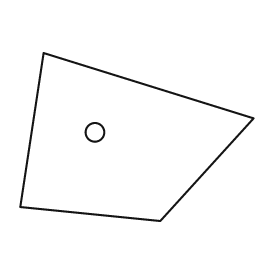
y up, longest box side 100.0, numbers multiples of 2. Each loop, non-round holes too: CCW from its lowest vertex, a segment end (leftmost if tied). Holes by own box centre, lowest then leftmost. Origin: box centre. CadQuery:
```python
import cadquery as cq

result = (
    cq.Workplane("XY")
    .moveTo(10.0, -36.0)
    .lineTo(50.0, 8.0)
    .lineTo(-40.0, 36.0)
    .lineTo(-50.0, -30.0)
    .close()
    .moveTo(-18.0, 2.0)
    .circle(4.0)
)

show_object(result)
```